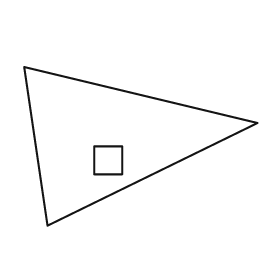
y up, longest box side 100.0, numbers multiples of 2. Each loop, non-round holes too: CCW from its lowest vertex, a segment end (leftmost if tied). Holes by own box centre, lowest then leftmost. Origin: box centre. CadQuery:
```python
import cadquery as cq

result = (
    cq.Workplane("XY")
    .moveTo(-40.0, -34.0)
    .lineTo(50.0, 10.0)
    .lineTo(-50.0, 34.0)
    .close()
    .moveTo(-20.0, -12.0)
    .lineTo(-8.0, -12.0)
    .lineTo(-8.0, 0.0)
    .lineTo(-20.0, 0.0)
    .close()
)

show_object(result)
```